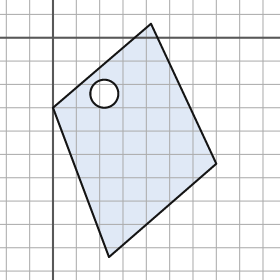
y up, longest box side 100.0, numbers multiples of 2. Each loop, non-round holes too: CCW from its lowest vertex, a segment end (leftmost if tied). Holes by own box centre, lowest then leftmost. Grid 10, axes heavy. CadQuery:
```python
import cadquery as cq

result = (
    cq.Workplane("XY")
    .moveTo(24.0, -94.0)
    .lineTo(70.0, -54.0)
    .lineTo(42.0, 6.0)
    .lineTo(0.0, -30.0)
    .close()
    .moveTo(22.0, -24.0)
    .circle(6.0)
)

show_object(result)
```